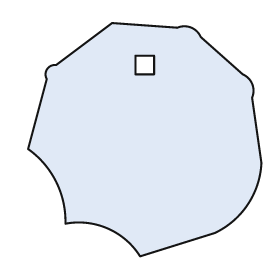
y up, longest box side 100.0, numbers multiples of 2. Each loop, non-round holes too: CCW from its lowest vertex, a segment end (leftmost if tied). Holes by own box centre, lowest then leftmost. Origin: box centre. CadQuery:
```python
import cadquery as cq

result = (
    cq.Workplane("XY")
    .moveTo(-2.0, -50.0)
    .lineTo(30.0, -40.0)
    .threePointArc((44.0, -28.0), (50.0, -10.0))
    .lineTo(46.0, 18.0)
    .threePointArc((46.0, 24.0), (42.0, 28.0))
    .lineTo(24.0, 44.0)
    .threePointArc((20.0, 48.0), (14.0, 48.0))
    .lineTo(-14.0, 50.0)
    .lineTo(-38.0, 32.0)
    .threePointArc((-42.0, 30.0), (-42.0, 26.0))
    .lineTo(-50.0, -4.0)
    .threePointArc((-38.0, -18.0), (-34.0, -36.0))
    .threePointArc((-16.0, -38.0), (-2.0, -50.0))
    .close()
    .moveTo(-4.0, 28.0)
    .lineTo(4.0, 28.0)
    .lineTo(4.0, 36.0)
    .lineTo(-4.0, 36.0)
    .close()
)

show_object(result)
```